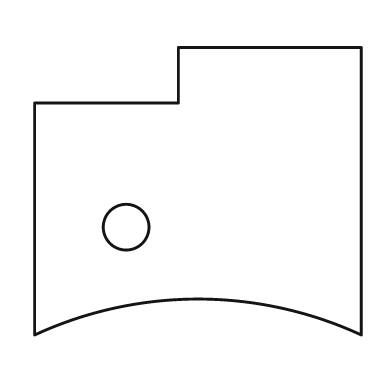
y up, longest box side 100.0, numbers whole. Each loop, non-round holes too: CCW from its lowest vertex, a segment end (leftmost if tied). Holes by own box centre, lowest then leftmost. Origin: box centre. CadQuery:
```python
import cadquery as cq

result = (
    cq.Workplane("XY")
    .moveTo(-50.0, -44.0)
    .threePointArc((0.0, -33.0), (50.0, -44.0))
    .lineTo(50.0, 44.0)
    .lineTo(-6.0, 44.0)
    .lineTo(-6.0, 27.0)
    .lineTo(-50.0, 27.0)
    .close()
    .moveTo(-22.0, -11.0)
    .circle(7.0)
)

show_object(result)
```